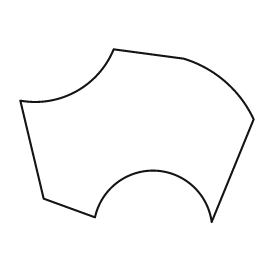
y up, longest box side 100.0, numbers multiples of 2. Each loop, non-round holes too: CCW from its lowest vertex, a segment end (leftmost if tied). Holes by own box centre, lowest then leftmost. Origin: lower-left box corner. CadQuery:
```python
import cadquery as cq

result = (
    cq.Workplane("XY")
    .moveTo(82.0, 0.0)
    .lineTo(100.0, 44.0)
    .threePointArc((88.0, 60.0), (70.0, 70.0))
    .lineTo(40.0, 74.0)
    .threePointArc((24.0, 56.0), (0.0, 52.0))
    .lineTo(10.0, 10.0)
    .lineTo(32.0, 2.0)
    .threePointArc((58.0, 22.0), (82.0, 0.0))
    .close()
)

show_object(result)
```